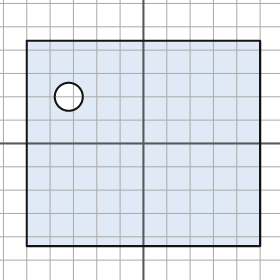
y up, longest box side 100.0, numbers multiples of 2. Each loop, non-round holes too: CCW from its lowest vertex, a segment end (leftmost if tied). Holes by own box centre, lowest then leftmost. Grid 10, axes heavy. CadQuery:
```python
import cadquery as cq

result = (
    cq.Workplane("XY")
    .moveTo(-50.0, -44.0)
    .lineTo(50.0, -44.0)
    .lineTo(50.0, 44.0)
    .lineTo(-50.0, 44.0)
    .close()
    .moveTo(-32.0, 20.0)
    .circle(6.0)
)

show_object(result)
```